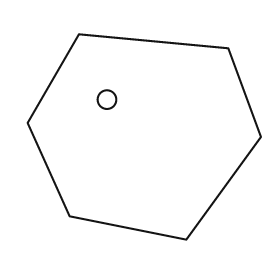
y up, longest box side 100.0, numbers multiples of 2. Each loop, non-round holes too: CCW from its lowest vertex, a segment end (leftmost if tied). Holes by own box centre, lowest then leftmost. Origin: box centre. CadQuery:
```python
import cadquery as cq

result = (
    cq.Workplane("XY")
    .moveTo(18.0, -44.0)
    .lineTo(50.0, 0.0)
    .lineTo(36.0, 38.0)
    .lineTo(-28.0, 44.0)
    .lineTo(-50.0, 6.0)
    .lineTo(-32.0, -34.0)
    .close()
    .moveTo(-16.0, 16.0)
    .circle(4.0)
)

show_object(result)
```